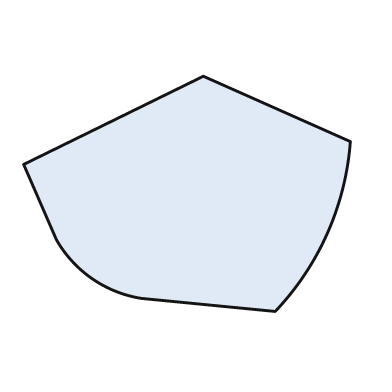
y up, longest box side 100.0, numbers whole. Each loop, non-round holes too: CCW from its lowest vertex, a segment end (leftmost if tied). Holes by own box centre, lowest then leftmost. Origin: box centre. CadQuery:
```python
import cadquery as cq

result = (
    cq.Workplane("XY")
    .moveTo(27.0, -36.0)
    .threePointArc((43.0, -12.0), (50.0, 16.0))
    .lineTo(5.0, 36.0)
    .lineTo(-50.0, 9.0)
    .lineTo(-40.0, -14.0)
    .threePointArc((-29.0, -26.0), (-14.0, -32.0))
    .close()
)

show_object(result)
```